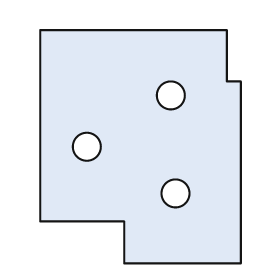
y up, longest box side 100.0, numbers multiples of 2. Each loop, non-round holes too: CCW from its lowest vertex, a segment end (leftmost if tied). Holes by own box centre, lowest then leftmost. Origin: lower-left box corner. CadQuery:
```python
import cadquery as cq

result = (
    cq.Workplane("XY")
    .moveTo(36.0, 0.0)
    .lineTo(86.0, 0.0)
    .lineTo(86.0, 78.0)
    .lineTo(80.0, 78.0)
    .lineTo(80.0, 100.0)
    .lineTo(0.0, 100.0)
    .lineTo(0.0, 18.0)
    .lineTo(36.0, 18.0)
    .close()
    .moveTo(58.0, 30.0)
    .circle(6.0)
    .moveTo(20.0, 50.0)
    .circle(6.0)
    .moveTo(56.0, 72.0)
    .circle(6.0)
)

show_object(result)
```